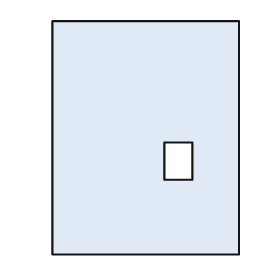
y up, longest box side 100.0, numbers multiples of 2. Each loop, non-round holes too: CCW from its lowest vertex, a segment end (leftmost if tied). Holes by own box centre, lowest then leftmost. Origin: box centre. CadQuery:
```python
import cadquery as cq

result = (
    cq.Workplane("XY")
    .moveTo(-40.0, -50.0)
    .lineTo(40.0, -50.0)
    .lineTo(40.0, 50.0)
    .lineTo(-40.0, 50.0)
    .close()
    .moveTo(8.0, -18.0)
    .lineTo(20.0, -18.0)
    .lineTo(20.0, -2.0)
    .lineTo(8.0, -2.0)
    .close()
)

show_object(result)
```